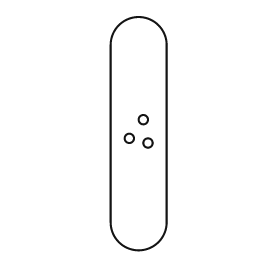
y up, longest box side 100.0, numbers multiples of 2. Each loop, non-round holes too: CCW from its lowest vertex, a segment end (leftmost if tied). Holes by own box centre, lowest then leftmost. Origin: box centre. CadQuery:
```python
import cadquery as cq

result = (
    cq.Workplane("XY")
    .moveTo(-12.0, -38.0)
    .threePointArc((0.0, -50.0), (12.0, -38.0))
    .lineTo(12.0, 38.0)
    .threePointArc((0.0, 50.0), (-12.0, 38.0))
    .close()
    .moveTo(4.0, -4.0)
    .circle(2.0)
    .moveTo(-4.0, -2.0)
    .circle(2.0)
    .moveTo(2.0, 6.0)
    .circle(2.0)
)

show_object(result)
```